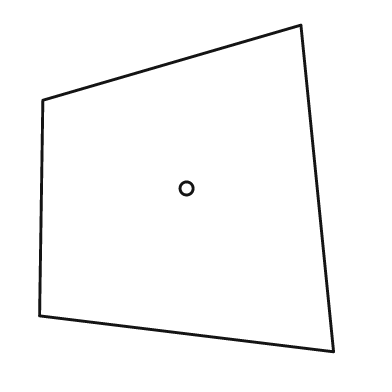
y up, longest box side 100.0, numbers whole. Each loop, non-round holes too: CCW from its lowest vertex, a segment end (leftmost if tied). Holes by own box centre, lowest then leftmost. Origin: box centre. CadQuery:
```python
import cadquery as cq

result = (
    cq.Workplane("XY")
    .moveTo(45.0, -50.0)
    .lineTo(35.0, 50.0)
    .lineTo(-44.0, 27.0)
    .lineTo(-45.0, -39.0)
    .close()
    .moveTo(0.0, 0.0)
    .circle(2.0)
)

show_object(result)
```